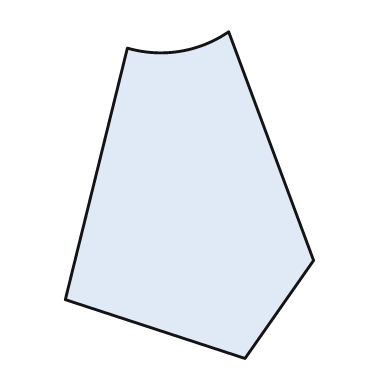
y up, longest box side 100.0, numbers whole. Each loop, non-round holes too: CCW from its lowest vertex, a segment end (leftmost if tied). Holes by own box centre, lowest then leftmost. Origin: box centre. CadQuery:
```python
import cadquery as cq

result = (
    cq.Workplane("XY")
    .moveTo(17.0, -50.0)
    .lineTo(38.0, -20.0)
    .lineTo(12.0, 50.0)
    .threePointArc((-3.0, 44.0), (-19.0, 45.0))
    .lineTo(-38.0, -32.0)
    .close()
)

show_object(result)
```